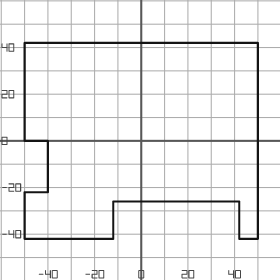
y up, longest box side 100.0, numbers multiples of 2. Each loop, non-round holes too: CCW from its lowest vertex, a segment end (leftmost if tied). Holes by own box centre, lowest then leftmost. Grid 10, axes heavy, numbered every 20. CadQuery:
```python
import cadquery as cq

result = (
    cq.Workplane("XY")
    .moveTo(-50.0, -42.0)
    .lineTo(-12.0, -42.0)
    .lineTo(-12.0, -26.0)
    .lineTo(42.0, -26.0)
    .lineTo(42.0, -42.0)
    .lineTo(50.0, -42.0)
    .lineTo(50.0, 42.0)
    .lineTo(-50.0, 42.0)
    .lineTo(-50.0, 0.0)
    .lineTo(-40.0, 0.0)
    .lineTo(-40.0, -22.0)
    .lineTo(-50.0, -22.0)
    .close()
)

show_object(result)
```